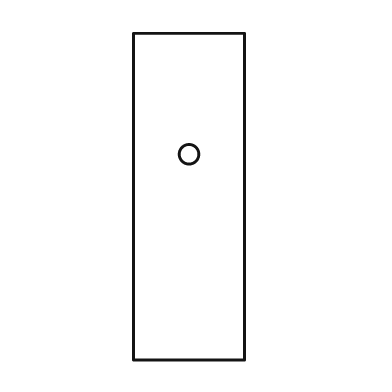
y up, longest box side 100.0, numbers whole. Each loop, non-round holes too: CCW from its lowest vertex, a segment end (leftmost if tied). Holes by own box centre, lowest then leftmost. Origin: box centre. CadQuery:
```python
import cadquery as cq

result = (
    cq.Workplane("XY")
    .moveTo(-17.0, -50.0)
    .lineTo(17.0, -50.0)
    .lineTo(17.0, 50.0)
    .lineTo(-17.0, 50.0)
    .close()
    .moveTo(0.0, 13.0)
    .circle(3.0)
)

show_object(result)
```